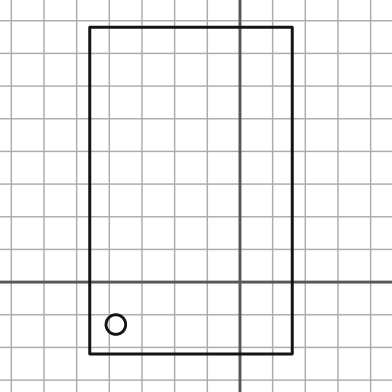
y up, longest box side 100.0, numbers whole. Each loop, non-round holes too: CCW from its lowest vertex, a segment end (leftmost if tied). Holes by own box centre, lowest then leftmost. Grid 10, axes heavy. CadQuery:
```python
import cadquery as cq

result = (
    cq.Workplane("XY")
    .moveTo(-46.0, -22.0)
    .lineTo(16.0, -22.0)
    .lineTo(16.0, 78.0)
    .lineTo(-46.0, 78.0)
    .close()
    .moveTo(-38.0, -13.0)
    .circle(3.0)
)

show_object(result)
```